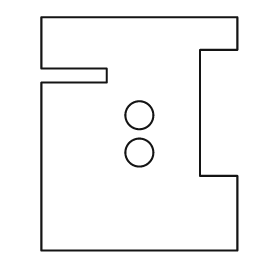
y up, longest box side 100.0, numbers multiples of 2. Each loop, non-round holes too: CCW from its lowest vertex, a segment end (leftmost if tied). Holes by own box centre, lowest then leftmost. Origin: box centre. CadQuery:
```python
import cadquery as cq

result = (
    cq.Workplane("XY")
    .moveTo(-42.0, -50.0)
    .lineTo(42.0, -50.0)
    .lineTo(42.0, -18.0)
    .lineTo(26.0, -18.0)
    .lineTo(26.0, 36.0)
    .lineTo(42.0, 36.0)
    .lineTo(42.0, 50.0)
    .lineTo(-42.0, 50.0)
    .lineTo(-42.0, 28.0)
    .lineTo(-14.0, 28.0)
    .lineTo(-14.0, 22.0)
    .lineTo(-42.0, 22.0)
    .close()
    .moveTo(0.0, -8.0)
    .circle(6.0)
    .moveTo(0.0, 8.0)
    .circle(6.0)
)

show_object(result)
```